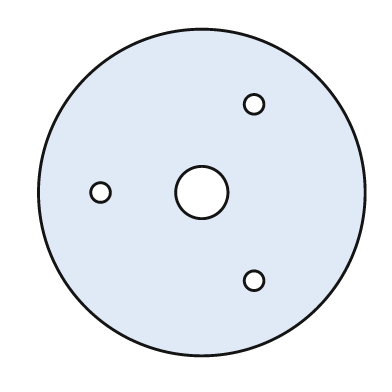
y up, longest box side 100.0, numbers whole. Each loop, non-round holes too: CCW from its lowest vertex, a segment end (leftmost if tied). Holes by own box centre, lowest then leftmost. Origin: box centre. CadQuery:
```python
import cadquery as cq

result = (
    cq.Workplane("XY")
    .moveTo(0.0, 0.0)
    .circle(50.0)
    .moveTo(16.0, -27.0)
    .circle(3.0)
    .moveTo(-31.0, 0.0)
    .circle(3.0)
    .moveTo(0.0, 0.0)
    .circle(8.0)
    .moveTo(16.0, 27.0)
    .circle(3.0)
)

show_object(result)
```